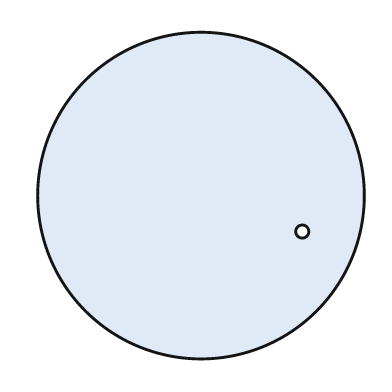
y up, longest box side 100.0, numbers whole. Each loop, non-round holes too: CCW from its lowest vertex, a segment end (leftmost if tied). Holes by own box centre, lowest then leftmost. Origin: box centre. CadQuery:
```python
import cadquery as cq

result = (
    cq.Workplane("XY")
    .moveTo(0.0, 0.0)
    .circle(50.0)
    .moveTo(31.0, -11.0)
    .circle(2.0)
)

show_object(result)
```